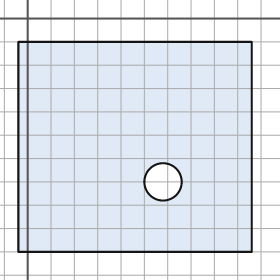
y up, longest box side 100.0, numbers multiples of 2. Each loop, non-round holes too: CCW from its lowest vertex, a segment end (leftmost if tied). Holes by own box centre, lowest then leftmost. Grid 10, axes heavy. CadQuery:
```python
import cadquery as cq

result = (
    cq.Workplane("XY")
    .moveTo(-4.0, -100.0)
    .lineTo(96.0, -100.0)
    .lineTo(96.0, -10.0)
    .lineTo(-4.0, -10.0)
    .close()
    .moveTo(58.0, -70.0)
    .circle(8.0)
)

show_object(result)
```